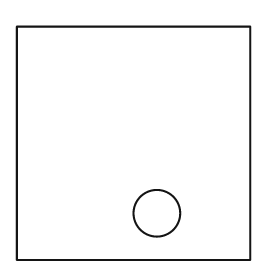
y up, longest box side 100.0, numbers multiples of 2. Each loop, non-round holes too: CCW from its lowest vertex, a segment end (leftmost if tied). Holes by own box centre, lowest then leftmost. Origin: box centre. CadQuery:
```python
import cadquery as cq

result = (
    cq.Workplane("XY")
    .moveTo(-50.0, -50.0)
    .lineTo(50.0, -50.0)
    .lineTo(50.0, 50.0)
    .lineTo(-50.0, 50.0)
    .close()
    .moveTo(10.0, -30.0)
    .circle(10.0)
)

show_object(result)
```